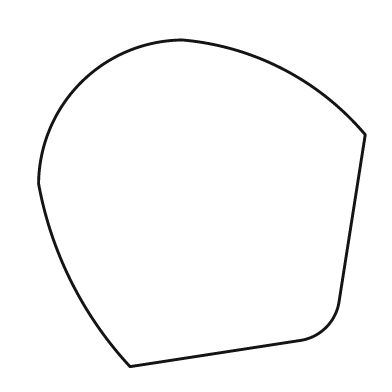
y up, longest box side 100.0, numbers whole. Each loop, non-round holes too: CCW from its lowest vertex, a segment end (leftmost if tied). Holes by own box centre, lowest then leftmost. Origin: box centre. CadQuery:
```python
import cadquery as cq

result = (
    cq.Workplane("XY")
    .moveTo(-22.0, -50.0)
    .lineTo(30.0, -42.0)
    .threePointArc((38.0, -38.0), (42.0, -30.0))
    .lineTo(50.0, 21.0)
    .threePointArc((25.0, 41.0), (-6.0, 50.0))
    .threePointArc((-37.0, 37.0), (-50.0, 6.0))
    .threePointArc((-40.0, -24.0), (-22.0, -50.0))
    .close()
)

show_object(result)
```